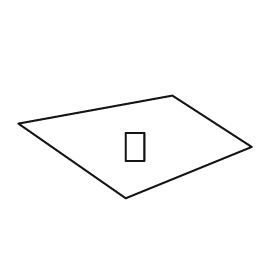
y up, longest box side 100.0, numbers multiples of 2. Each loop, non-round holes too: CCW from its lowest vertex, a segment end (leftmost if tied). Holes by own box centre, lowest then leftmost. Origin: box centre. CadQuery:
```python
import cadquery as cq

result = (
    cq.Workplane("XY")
    .moveTo(-4.0, -22.0)
    .lineTo(50.0, 0.0)
    .lineTo(16.0, 22.0)
    .lineTo(-50.0, 10.0)
    .close()
    .moveTo(-4.0, -6.0)
    .lineTo(4.0, -6.0)
    .lineTo(4.0, 6.0)
    .lineTo(-4.0, 6.0)
    .close()
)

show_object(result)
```